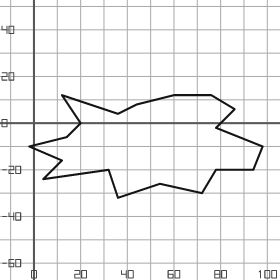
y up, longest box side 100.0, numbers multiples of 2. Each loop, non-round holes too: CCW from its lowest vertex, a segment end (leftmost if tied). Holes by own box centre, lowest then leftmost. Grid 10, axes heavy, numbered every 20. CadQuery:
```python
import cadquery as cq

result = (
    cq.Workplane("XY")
    .moveTo(36.0, -32.0)
    .lineTo(54.0, -26.0)
    .lineTo(72.0, -30.0)
    .lineTo(78.0, -20.0)
    .lineTo(94.0, -20.0)
    .lineTo(98.0, -10.0)
    .lineTo(78.0, -2.0)
    .lineTo(86.0, 6.0)
    .lineTo(76.0, 12.0)
    .lineTo(60.0, 12.0)
    .lineTo(44.0, 8.0)
    .lineTo(36.0, 4.0)
    .lineTo(12.0, 12.0)
    .lineTo(20.0, 0.0)
    .lineTo(14.0, -6.0)
    .lineTo(-2.0, -10.0)
    .lineTo(12.0, -16.0)
    .lineTo(4.0, -24.0)
    .lineTo(32.0, -20.0)
    .close()
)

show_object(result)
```